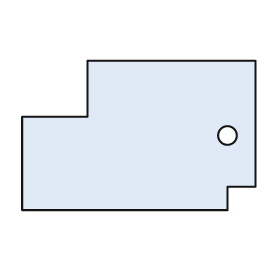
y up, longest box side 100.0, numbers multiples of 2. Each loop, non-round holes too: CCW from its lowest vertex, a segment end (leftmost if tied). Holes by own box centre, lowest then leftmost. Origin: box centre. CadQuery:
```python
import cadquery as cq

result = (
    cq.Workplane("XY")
    .moveTo(-50.0, -32.0)
    .lineTo(38.0, -32.0)
    .lineTo(38.0, -22.0)
    .lineTo(50.0, -22.0)
    .lineTo(50.0, 32.0)
    .lineTo(-22.0, 32.0)
    .lineTo(-22.0, 8.0)
    .lineTo(-50.0, 8.0)
    .close()
    .moveTo(38.0, 0.0)
    .circle(4.0)
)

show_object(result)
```